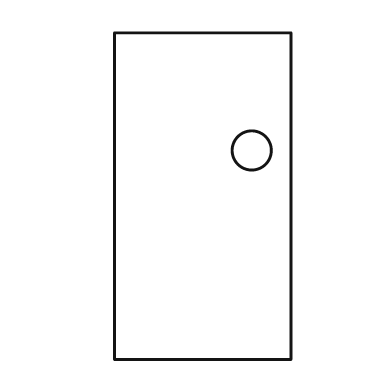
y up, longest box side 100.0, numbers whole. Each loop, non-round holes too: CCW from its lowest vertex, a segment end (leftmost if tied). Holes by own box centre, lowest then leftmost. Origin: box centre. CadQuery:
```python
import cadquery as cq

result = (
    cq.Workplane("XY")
    .moveTo(-27.0, -50.0)
    .lineTo(27.0, -50.0)
    .lineTo(27.0, 50.0)
    .lineTo(-27.0, 50.0)
    .close()
    .moveTo(15.0, 14.0)
    .circle(6.0)
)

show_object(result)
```